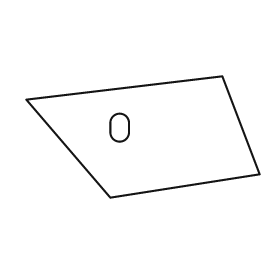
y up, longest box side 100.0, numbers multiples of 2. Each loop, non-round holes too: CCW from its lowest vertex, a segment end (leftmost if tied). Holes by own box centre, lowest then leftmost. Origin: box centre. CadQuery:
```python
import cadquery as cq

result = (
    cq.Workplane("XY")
    .moveTo(-14.0, -26.0)
    .lineTo(50.0, -16.0)
    .lineTo(34.0, 26.0)
    .lineTo(-50.0, 16.0)
    .close()
    .moveTo(-14.0, 2.0)
    .threePointArc((-10.0, -2.0), (-6.0, 2.0))
    .lineTo(-6.0, 6.0)
    .threePointArc((-10.0, 10.0), (-14.0, 6.0))
    .close()
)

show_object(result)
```